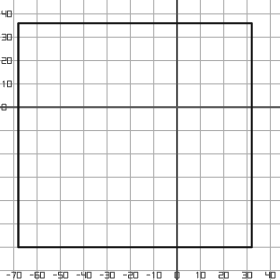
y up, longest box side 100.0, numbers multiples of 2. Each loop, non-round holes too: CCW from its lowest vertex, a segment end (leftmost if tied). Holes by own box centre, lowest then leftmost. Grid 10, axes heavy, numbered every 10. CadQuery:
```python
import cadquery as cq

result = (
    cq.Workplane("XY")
    .moveTo(-68.0, -60.0)
    .lineTo(32.0, -60.0)
    .lineTo(32.0, 36.0)
    .lineTo(-68.0, 36.0)
    .close()
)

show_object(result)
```